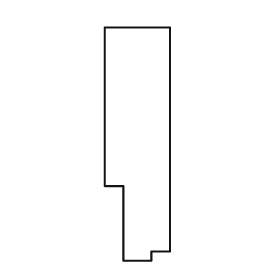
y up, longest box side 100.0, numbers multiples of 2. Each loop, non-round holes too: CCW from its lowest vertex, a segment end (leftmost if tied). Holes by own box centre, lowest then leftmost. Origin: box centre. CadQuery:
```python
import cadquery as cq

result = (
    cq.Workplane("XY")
    .moveTo(-6.0, -50.0)
    .lineTo(6.0, -50.0)
    .lineTo(6.0, -46.0)
    .lineTo(14.0, -46.0)
    .lineTo(14.0, 50.0)
    .lineTo(-14.0, 50.0)
    .lineTo(-14.0, -18.0)
    .lineTo(-6.0, -18.0)
    .close()
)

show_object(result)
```